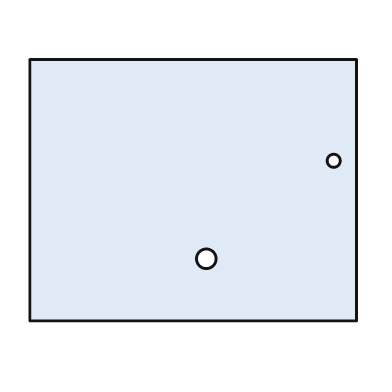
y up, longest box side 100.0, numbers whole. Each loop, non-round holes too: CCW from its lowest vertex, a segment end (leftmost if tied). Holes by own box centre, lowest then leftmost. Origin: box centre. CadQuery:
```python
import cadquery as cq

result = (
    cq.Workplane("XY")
    .moveTo(-50.0, -40.0)
    .lineTo(50.0, -40.0)
    .lineTo(50.0, 40.0)
    .lineTo(-50.0, 40.0)
    .close()
    .moveTo(4.0, -21.0)
    .circle(3.0)
    .moveTo(43.0, 9.0)
    .circle(2.0)
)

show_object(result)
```